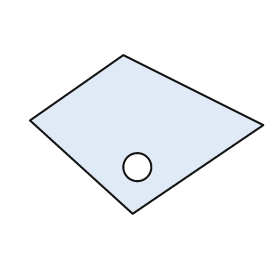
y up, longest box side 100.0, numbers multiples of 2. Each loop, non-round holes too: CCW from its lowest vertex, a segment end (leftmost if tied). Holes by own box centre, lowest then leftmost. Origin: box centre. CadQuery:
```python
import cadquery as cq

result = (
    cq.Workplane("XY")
    .moveTo(-6.0, -34.0)
    .lineTo(50.0, 4.0)
    .lineTo(-10.0, 34.0)
    .lineTo(-50.0, 6.0)
    .close()
    .moveTo(-4.0, -14.0)
    .circle(6.0)
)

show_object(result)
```